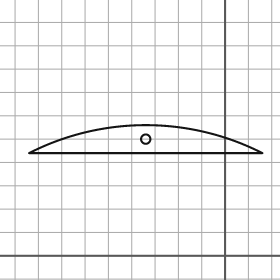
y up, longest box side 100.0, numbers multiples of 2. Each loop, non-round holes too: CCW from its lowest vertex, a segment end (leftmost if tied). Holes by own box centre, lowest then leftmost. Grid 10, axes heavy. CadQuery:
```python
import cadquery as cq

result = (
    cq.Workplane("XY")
    .moveTo(-84.0, 44.0)
    .lineTo(16.0, 44.0)
    .threePointArc((-34.0, 56.0), (-84.0, 44.0))
    .close()
    .moveTo(-34.0, 50.0)
    .circle(2.0)
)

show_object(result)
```